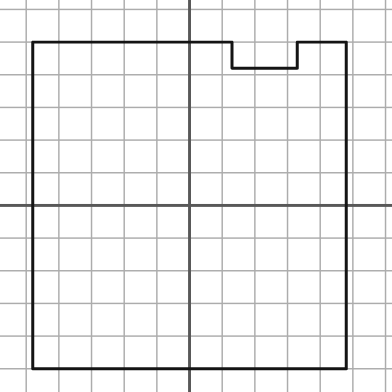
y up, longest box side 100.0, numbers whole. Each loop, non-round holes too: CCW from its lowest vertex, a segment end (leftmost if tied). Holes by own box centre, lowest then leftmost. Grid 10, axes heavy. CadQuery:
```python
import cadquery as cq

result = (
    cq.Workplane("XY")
    .moveTo(-48.0, -50.0)
    .lineTo(48.0, -50.0)
    .lineTo(48.0, 50.0)
    .lineTo(33.0, 50.0)
    .lineTo(33.0, 42.0)
    .lineTo(13.0, 42.0)
    .lineTo(13.0, 50.0)
    .lineTo(-48.0, 50.0)
    .close()
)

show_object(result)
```